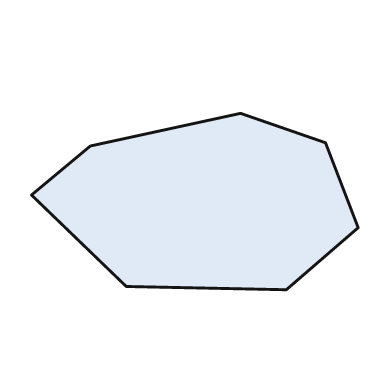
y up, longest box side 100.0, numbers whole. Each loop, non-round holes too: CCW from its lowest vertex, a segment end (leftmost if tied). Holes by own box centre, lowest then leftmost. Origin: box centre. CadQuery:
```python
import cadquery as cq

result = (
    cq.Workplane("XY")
    .moveTo(28.0, -27.0)
    .lineTo(50.0, -8.0)
    .lineTo(40.0, 18.0)
    .lineTo(14.0, 27.0)
    .lineTo(-32.0, 17.0)
    .lineTo(-50.0, 2.0)
    .lineTo(-21.0, -26.0)
    .close()
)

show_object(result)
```